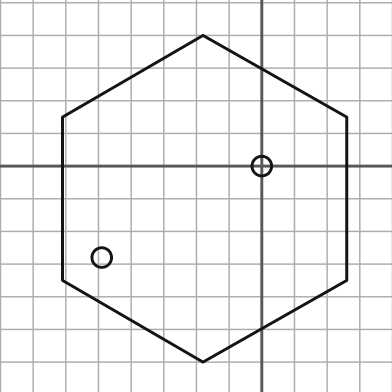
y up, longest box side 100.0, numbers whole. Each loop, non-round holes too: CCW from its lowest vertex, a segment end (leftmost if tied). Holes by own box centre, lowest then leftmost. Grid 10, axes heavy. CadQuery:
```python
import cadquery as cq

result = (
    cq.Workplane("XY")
    .moveTo(-18.0, -60.0)
    .lineTo(26.0, -35.0)
    .lineTo(26.0, 15.0)
    .lineTo(-18.0, 40.0)
    .lineTo(-61.0, 15.0)
    .lineTo(-61.0, -35.0)
    .close()
    .moveTo(-49.0, -28.0)
    .circle(3.0)
    .moveTo(0.0, 0.0)
    .circle(3.0)
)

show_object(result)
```